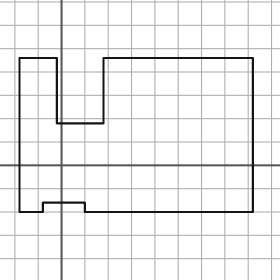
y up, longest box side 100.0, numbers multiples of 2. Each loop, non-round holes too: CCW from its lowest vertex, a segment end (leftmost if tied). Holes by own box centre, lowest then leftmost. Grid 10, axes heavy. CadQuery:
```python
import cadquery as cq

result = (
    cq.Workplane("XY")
    .moveTo(-18.0, -20.0)
    .lineTo(-8.0, -20.0)
    .lineTo(-8.0, -16.0)
    .lineTo(10.0, -16.0)
    .lineTo(10.0, -20.0)
    .lineTo(82.0, -20.0)
    .lineTo(82.0, 46.0)
    .lineTo(18.0, 46.0)
    .lineTo(18.0, 18.0)
    .lineTo(-2.0, 18.0)
    .lineTo(-2.0, 46.0)
    .lineTo(-18.0, 46.0)
    .close()
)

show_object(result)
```